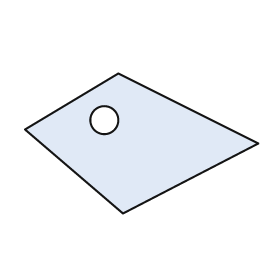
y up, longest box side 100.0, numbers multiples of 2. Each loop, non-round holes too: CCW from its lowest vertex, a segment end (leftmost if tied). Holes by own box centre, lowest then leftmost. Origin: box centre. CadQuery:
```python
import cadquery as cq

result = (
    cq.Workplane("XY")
    .moveTo(-8.0, -30.0)
    .lineTo(50.0, 0.0)
    .lineTo(-10.0, 30.0)
    .lineTo(-50.0, 6.0)
    .close()
    .moveTo(-16.0, 10.0)
    .circle(6.0)
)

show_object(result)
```